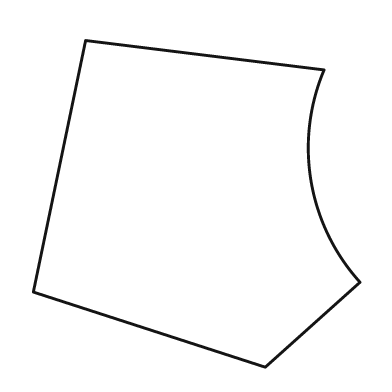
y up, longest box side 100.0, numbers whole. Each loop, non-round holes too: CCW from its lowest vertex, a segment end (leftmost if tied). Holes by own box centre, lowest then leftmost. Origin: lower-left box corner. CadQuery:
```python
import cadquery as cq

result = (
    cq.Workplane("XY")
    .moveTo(71.0, 0.0)
    .lineTo(100.0, 26.0)
    .threePointArc((85.0, 57.0), (89.0, 91.0))
    .lineTo(16.0, 100.0)
    .lineTo(0.0, 23.0)
    .close()
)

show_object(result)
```